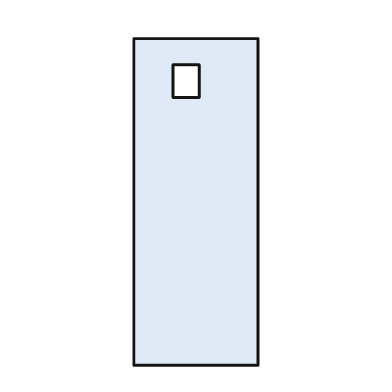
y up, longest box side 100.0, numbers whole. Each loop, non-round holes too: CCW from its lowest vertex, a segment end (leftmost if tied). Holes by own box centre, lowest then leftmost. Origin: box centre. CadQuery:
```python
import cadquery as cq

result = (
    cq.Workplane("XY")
    .moveTo(-19.0, -50.0)
    .lineTo(19.0, -50.0)
    .lineTo(19.0, 50.0)
    .lineTo(-19.0, 50.0)
    .close()
    .moveTo(-7.0, 32.0)
    .lineTo(1.0, 32.0)
    .lineTo(1.0, 42.0)
    .lineTo(-7.0, 42.0)
    .close()
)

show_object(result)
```